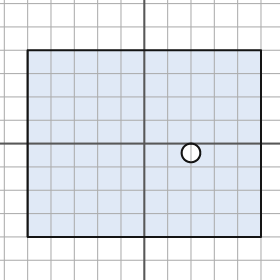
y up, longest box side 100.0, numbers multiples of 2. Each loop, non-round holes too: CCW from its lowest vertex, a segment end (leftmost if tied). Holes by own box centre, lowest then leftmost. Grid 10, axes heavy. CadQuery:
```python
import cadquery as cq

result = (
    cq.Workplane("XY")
    .moveTo(-50.0, -40.0)
    .lineTo(50.0, -40.0)
    .lineTo(50.0, 40.0)
    .lineTo(-50.0, 40.0)
    .close()
    .moveTo(20.0, -4.0)
    .circle(4.0)
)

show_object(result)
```